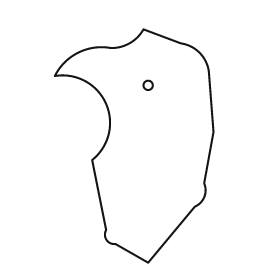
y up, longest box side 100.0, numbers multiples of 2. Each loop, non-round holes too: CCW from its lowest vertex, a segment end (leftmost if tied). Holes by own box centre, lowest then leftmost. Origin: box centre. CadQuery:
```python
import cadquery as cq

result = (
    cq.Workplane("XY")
    .moveTo(6.0, -50.0)
    .lineTo(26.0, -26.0)
    .threePointArc((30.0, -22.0), (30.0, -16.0))
    .lineTo(34.0, 6.0)
    .lineTo(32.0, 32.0)
    .threePointArc((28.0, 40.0), (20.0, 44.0))
    .lineTo(4.0, 50.0)
    .threePointArc((-2.0, 44.0), (-10.0, 42.0))
    .threePointArc((-24.0, 40.0), (-34.0, 30.0))
    .threePointArc((-12.0, 18.0), (-18.0, -6.0))
    .lineTo(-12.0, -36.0)
    .threePointArc((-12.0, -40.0), (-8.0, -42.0))
    .close()
    .moveTo(6.0, 26.0)
    .circle(2.0)
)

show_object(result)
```